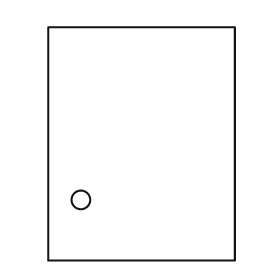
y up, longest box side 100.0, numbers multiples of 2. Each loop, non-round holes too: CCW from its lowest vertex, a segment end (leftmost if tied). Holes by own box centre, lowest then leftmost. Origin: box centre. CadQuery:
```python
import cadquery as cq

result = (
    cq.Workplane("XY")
    .moveTo(-40.0, -50.0)
    .lineTo(40.0, -50.0)
    .lineTo(40.0, 50.0)
    .lineTo(-40.0, 50.0)
    .close()
    .moveTo(-26.0, -24.0)
    .circle(4.0)
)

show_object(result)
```